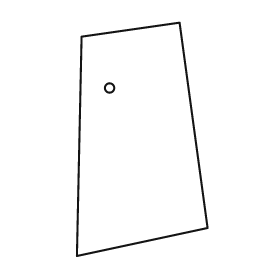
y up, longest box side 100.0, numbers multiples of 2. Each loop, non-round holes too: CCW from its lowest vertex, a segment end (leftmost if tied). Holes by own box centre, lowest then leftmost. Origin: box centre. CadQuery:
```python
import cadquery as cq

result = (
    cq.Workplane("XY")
    .moveTo(-28.0, -50.0)
    .lineTo(28.0, -38.0)
    .lineTo(16.0, 50.0)
    .lineTo(-26.0, 44.0)
    .close()
    .moveTo(-14.0, 22.0)
    .circle(2.0)
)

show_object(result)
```